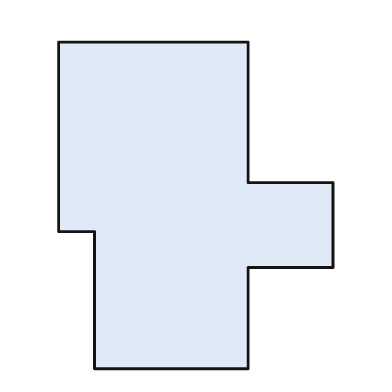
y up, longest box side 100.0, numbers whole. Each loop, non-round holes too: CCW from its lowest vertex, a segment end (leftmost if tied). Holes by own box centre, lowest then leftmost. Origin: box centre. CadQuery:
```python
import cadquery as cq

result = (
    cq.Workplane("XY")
    .moveTo(-31.0, -50.0)
    .lineTo(16.0, -50.0)
    .lineTo(16.0, -19.0)
    .lineTo(42.0, -19.0)
    .lineTo(42.0, 7.0)
    .lineTo(16.0, 7.0)
    .lineTo(16.0, 50.0)
    .lineTo(-42.0, 50.0)
    .lineTo(-42.0, -8.0)
    .lineTo(-31.0, -8.0)
    .close()
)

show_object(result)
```